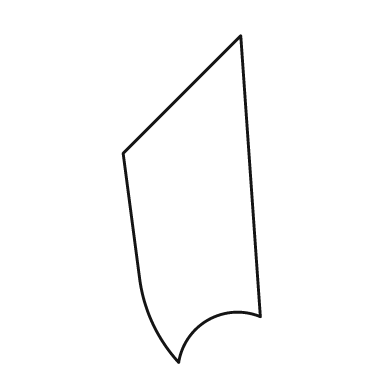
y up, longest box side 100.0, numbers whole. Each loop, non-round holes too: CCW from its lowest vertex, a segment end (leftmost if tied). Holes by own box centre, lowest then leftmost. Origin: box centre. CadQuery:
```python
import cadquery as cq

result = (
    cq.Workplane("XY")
    .moveTo(-4.0, -50.0)
    .threePointArc((5.0, -37.0), (21.0, -36.0))
    .lineTo(15.0, 50.0)
    .lineTo(-21.0, 14.0)
    .lineTo(-16.0, -24.0)
    .threePointArc((-12.0, -38.0), (-4.0, -50.0))
    .close()
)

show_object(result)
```